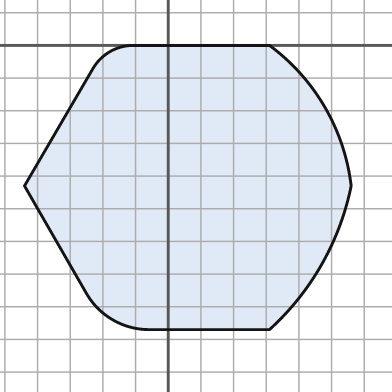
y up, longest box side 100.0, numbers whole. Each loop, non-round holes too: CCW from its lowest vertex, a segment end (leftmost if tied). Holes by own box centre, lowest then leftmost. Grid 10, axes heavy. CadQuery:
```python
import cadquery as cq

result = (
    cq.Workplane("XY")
    .moveTo(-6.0, -87.0)
    .lineTo(31.0, -87.0)
    .threePointArc((47.0, -67.0), (56.0, -43.0))
    .threePointArc((48.0, -19.0), (31.0, 0.0))
    .lineTo(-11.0, 0.0)
    .threePointArc((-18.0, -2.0), (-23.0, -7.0))
    .lineTo(-44.0, -43.0)
    .lineTo(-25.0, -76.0)
    .threePointArc((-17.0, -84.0), (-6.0, -87.0))
    .close()
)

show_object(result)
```